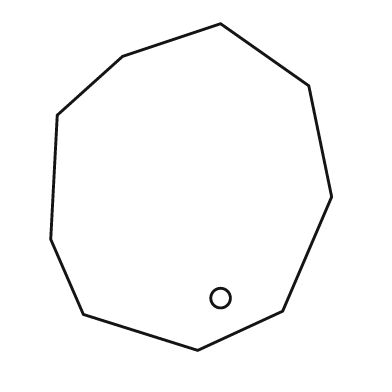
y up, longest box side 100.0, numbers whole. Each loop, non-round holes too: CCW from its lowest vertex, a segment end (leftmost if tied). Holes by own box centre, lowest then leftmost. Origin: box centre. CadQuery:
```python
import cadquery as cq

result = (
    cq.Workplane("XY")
    .moveTo(2.0, -50.0)
    .lineTo(28.0, -38.0)
    .lineTo(43.0, -3.0)
    .lineTo(36.0, 31.0)
    .lineTo(9.0, 50.0)
    .lineTo(-21.0, 40.0)
    .lineTo(-41.0, 22.0)
    .lineTo(-43.0, -16.0)
    .lineTo(-33.0, -39.0)
    .close()
    .moveTo(9.0, -34.0)
    .circle(3.0)
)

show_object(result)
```